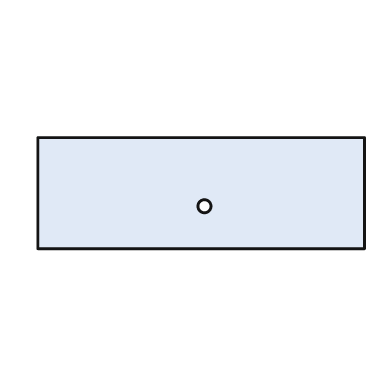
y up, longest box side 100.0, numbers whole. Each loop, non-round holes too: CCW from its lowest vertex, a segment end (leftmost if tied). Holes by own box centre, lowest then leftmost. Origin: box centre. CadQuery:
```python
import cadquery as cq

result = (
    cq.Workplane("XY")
    .moveTo(-50.0, -17.0)
    .lineTo(50.0, -17.0)
    .lineTo(50.0, 17.0)
    .lineTo(-50.0, 17.0)
    .close()
    .moveTo(1.0, -4.0)
    .circle(2.0)
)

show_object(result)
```